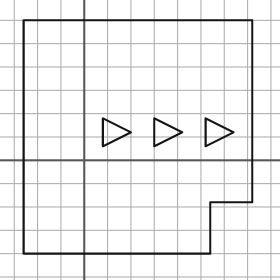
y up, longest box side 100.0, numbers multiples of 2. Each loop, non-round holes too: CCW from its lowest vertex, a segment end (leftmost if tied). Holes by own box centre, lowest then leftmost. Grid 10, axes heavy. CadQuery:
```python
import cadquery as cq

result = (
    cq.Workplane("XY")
    .moveTo(-26.0, -40.0)
    .lineTo(54.0, -40.0)
    .lineTo(54.0, -18.0)
    .lineTo(72.0, -18.0)
    .lineTo(72.0, 60.0)
    .lineTo(-26.0, 60.0)
    .close()
    .moveTo(8.0, 6.0)
    .lineTo(20.0, 12.0)
    .lineTo(8.0, 18.0)
    .close()
    .moveTo(30.0, 6.0)
    .lineTo(42.0, 12.0)
    .lineTo(30.0, 18.0)
    .close()
    .moveTo(52.0, 6.0)
    .lineTo(64.0, 12.0)
    .lineTo(52.0, 18.0)
    .close()
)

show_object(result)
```